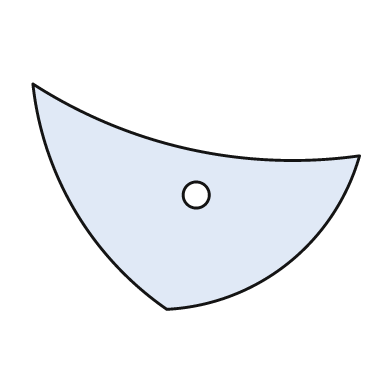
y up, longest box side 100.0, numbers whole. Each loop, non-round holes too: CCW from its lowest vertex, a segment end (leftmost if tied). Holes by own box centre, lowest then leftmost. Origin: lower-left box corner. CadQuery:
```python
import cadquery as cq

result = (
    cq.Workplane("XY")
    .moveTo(41.0, 0.0)
    .threePointArc((78.0, 14.0), (100.0, 47.0))
    .threePointArc((48.0, 49.0), (0.0, 69.0))
    .threePointArc((13.0, 30.0), (41.0, 0.0))
    .close()
    .moveTo(50.0, 35.0)
    .circle(4.0)
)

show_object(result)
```